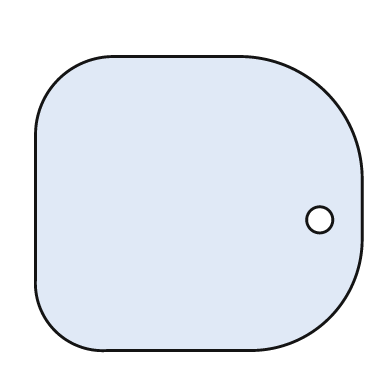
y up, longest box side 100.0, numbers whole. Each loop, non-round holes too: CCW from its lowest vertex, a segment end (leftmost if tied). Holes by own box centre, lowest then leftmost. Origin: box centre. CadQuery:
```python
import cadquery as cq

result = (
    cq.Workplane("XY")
    .moveTo(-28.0, -45.0)
    .lineTo(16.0, -45.0)
    .threePointArc((40.0, -35.0), (50.0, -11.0))
    .lineTo(50.0, 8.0)
    .threePointArc((39.0, 34.0), (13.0, 45.0))
    .lineTo(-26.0, 45.0)
    .threePointArc((-43.0, 38.0), (-50.0, 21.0))
    .lineTo(-50.0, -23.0)
    .threePointArc((-44.0, -39.0), (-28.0, -45.0))
    .close()
    .moveTo(37.0, -5.0)
    .circle(4.0)
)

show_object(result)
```